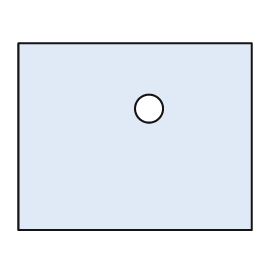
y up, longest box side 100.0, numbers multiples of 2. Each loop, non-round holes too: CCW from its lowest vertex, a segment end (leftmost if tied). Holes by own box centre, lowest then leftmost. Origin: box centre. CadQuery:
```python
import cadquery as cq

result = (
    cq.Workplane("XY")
    .moveTo(-50.0, -40.0)
    .lineTo(50.0, -40.0)
    .lineTo(50.0, 40.0)
    .lineTo(-50.0, 40.0)
    .close()
    .moveTo(6.0, 12.0)
    .circle(6.0)
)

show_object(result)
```